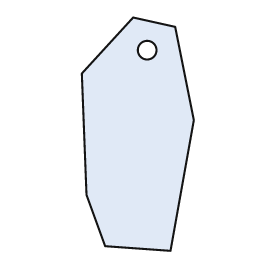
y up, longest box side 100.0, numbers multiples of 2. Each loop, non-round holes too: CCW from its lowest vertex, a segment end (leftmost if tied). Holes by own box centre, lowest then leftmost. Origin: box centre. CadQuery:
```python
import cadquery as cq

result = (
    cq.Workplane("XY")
    .moveTo(14.0, -50.0)
    .lineTo(24.0, 6.0)
    .lineTo(16.0, 46.0)
    .lineTo(-2.0, 50.0)
    .lineTo(-24.0, 26.0)
    .lineTo(-22.0, -26.0)
    .lineTo(-14.0, -48.0)
    .close()
    .moveTo(4.0, 36.0)
    .circle(4.0)
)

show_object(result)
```